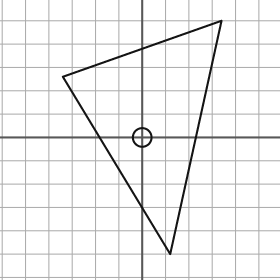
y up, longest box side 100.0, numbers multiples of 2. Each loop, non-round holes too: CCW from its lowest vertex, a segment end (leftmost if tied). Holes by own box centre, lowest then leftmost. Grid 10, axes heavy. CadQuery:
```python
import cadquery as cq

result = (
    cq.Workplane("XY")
    .moveTo(12.0, -50.0)
    .lineTo(34.0, 50.0)
    .lineTo(-34.0, 26.0)
    .close()
    .moveTo(0.0, 0.0)
    .circle(4.0)
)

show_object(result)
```